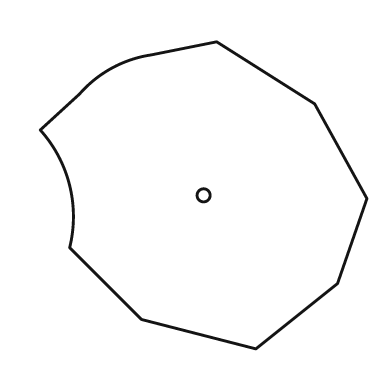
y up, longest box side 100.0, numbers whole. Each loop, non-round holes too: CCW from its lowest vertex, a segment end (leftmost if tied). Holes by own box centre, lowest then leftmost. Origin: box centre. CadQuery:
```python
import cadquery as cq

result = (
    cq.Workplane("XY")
    .moveTo(16.0, -47.0)
    .lineTo(41.0, -27.0)
    .lineTo(50.0, -1.0)
    .lineTo(34.0, 28.0)
    .lineTo(4.0, 47.0)
    .lineTo(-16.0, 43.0)
    .threePointArc((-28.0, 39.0), (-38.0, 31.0))
    .lineTo(-50.0, 20.0)
    .threePointArc((-41.0, 3.0), (-41.0, -16.0))
    .lineTo(-19.0, -38.0)
    .close()
    .moveTo(0.0, 0.0)
    .circle(2.0)
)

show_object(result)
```